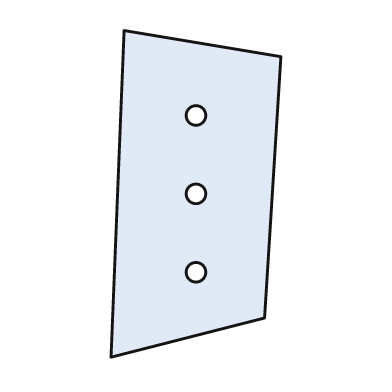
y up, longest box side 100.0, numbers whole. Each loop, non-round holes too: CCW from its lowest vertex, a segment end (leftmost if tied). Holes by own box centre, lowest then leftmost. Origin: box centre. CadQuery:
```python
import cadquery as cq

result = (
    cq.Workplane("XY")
    .moveTo(-26.0, -50.0)
    .lineTo(21.0, -38.0)
    .lineTo(26.0, 42.0)
    .lineTo(-22.0, 50.0)
    .close()
    .moveTo(0.0, -24.0)
    .circle(3.0)
    .moveTo(0.0, 0.0)
    .circle(3.0)
    .moveTo(0.0, 24.0)
    .circle(3.0)
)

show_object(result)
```